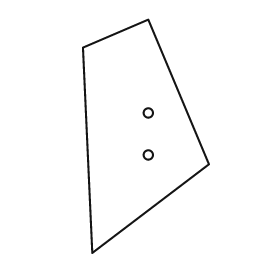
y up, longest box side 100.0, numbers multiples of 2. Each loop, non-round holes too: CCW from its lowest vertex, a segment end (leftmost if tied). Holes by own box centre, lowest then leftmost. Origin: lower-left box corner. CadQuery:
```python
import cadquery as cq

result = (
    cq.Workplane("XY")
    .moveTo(4.0, 0.0)
    .lineTo(54.0, 38.0)
    .lineTo(28.0, 100.0)
    .lineTo(0.0, 88.0)
    .close()
    .moveTo(28.0, 42.0)
    .circle(2.0)
    .moveTo(28.0, 60.0)
    .circle(2.0)
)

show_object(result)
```